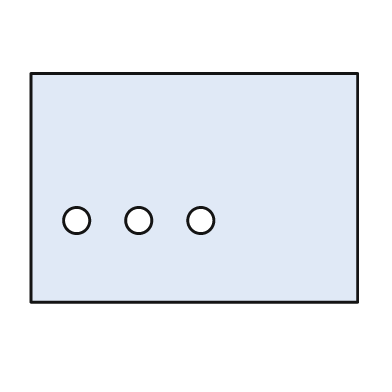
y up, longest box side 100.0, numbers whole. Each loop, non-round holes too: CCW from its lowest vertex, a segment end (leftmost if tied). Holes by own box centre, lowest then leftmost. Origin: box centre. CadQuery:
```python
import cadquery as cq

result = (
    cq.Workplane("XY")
    .moveTo(-50.0, -35.0)
    .lineTo(50.0, -35.0)
    .lineTo(50.0, 35.0)
    .lineTo(-50.0, 35.0)
    .close()
    .moveTo(-36.0, -10.0)
    .circle(4.0)
    .moveTo(-17.0, -10.0)
    .circle(4.0)
    .moveTo(2.0, -10.0)
    .circle(4.0)
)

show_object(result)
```